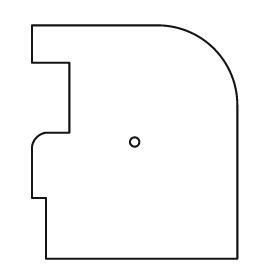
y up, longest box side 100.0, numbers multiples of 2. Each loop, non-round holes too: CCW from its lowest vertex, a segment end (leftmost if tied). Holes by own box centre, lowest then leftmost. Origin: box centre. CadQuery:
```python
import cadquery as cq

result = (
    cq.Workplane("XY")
    .moveTo(-38.0, -50.0)
    .lineTo(44.0, -50.0)
    .lineTo(44.0, 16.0)
    .threePointArc((34.0, 40.0), (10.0, 50.0))
    .lineTo(-44.0, 50.0)
    .lineTo(-44.0, 34.0)
    .lineTo(-28.0, 34.0)
    .lineTo(-28.0, 4.0)
    .lineTo(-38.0, 4.0)
    .threePointArc((-42.0, 2.0), (-44.0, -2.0))
    .lineTo(-44.0, -24.0)
    .lineTo(-38.0, -24.0)
    .close()
    .moveTo(0.0, 0.0)
    .circle(2.0)
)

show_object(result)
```